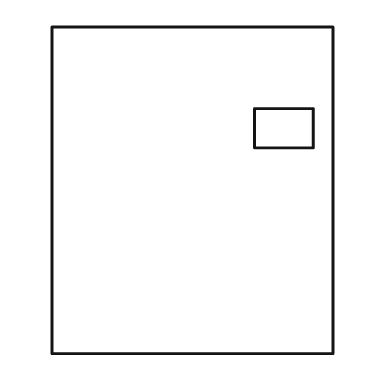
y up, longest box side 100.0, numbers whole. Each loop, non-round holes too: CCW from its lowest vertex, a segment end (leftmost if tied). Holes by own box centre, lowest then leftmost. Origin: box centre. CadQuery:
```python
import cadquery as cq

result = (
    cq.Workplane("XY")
    .moveTo(-43.0, -50.0)
    .lineTo(43.0, -50.0)
    .lineTo(43.0, 50.0)
    .lineTo(-43.0, 50.0)
    .close()
    .moveTo(19.0, 13.0)
    .lineTo(37.0, 13.0)
    .lineTo(37.0, 25.0)
    .lineTo(19.0, 25.0)
    .close()
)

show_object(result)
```